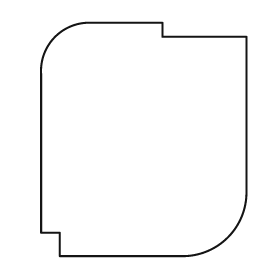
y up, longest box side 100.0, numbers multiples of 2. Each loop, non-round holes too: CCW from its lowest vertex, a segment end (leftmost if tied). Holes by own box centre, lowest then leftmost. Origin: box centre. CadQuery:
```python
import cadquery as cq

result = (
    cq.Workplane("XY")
    .moveTo(-36.0, -50.0)
    .lineTo(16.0, -50.0)
    .threePointArc((36.0, -42.0), (44.0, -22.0))
    .lineTo(44.0, 44.0)
    .lineTo(8.0, 44.0)
    .lineTo(8.0, 50.0)
    .lineTo(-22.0, 50.0)
    .threePointArc((-38.0, 44.0), (-44.0, 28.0))
    .lineTo(-44.0, -40.0)
    .lineTo(-36.0, -40.0)
    .close()
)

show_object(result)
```